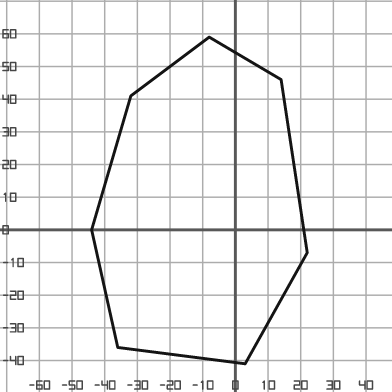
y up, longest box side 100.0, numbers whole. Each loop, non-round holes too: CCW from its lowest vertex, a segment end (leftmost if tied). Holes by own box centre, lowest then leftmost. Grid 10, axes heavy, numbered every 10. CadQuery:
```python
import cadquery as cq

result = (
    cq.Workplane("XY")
    .moveTo(3.0, -41.0)
    .lineTo(22.0, -7.0)
    .lineTo(14.0, 46.0)
    .lineTo(-8.0, 59.0)
    .lineTo(-32.0, 41.0)
    .lineTo(-44.0, 0.0)
    .lineTo(-36.0, -36.0)
    .close()
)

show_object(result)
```